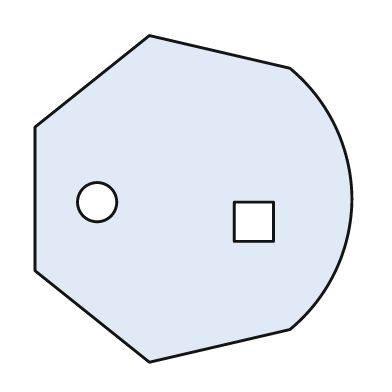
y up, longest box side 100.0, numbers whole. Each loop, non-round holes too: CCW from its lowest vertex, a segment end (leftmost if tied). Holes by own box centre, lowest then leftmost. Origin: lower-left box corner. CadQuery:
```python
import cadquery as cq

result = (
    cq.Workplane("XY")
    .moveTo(35.0, 0.0)
    .lineTo(78.0, 10.0)
    .threePointArc((92.0, 28.0), (97.0, 50.0))
    .threePointArc((92.0, 72.0), (78.0, 90.0))
    .lineTo(35.0, 100.0)
    .lineTo(0.0, 72.0)
    .lineTo(0.0, 28.0)
    .close()
    .moveTo(61.0, 37.0)
    .lineTo(73.0, 37.0)
    .lineTo(73.0, 49.0)
    .lineTo(61.0, 49.0)
    .close()
    .moveTo(19.0, 49.0)
    .circle(6.0)
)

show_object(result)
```